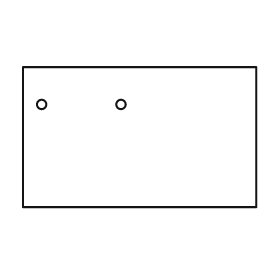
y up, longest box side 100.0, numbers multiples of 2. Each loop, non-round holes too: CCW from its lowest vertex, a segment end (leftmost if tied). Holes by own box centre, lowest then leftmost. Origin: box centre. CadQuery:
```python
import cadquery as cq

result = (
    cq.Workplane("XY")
    .moveTo(-50.0, -30.0)
    .lineTo(50.0, -30.0)
    .lineTo(50.0, 30.0)
    .lineTo(-50.0, 30.0)
    .close()
    .moveTo(-42.0, 14.0)
    .circle(2.0)
    .moveTo(-8.0, 14.0)
    .circle(2.0)
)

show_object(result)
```